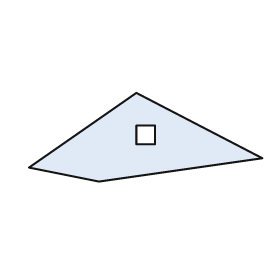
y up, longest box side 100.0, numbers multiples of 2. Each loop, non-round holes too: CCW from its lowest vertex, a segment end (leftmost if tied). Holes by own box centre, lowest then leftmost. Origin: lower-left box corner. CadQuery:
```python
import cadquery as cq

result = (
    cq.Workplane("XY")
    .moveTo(30.0, 0.0)
    .lineTo(100.0, 10.0)
    .lineTo(46.0, 38.0)
    .lineTo(0.0, 6.0)
    .close()
    .moveTo(46.0, 16.0)
    .lineTo(54.0, 16.0)
    .lineTo(54.0, 24.0)
    .lineTo(46.0, 24.0)
    .close()
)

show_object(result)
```